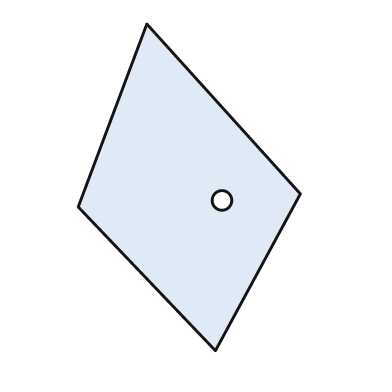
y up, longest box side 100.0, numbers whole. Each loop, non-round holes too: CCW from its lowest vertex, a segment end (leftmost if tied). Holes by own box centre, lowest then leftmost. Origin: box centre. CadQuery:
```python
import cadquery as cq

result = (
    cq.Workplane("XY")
    .moveTo(8.0, -50.0)
    .lineTo(34.0, -2.0)
    .lineTo(-13.0, 50.0)
    .lineTo(-34.0, -6.0)
    .close()
    .moveTo(10.0, -4.0)
    .circle(3.0)
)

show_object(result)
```